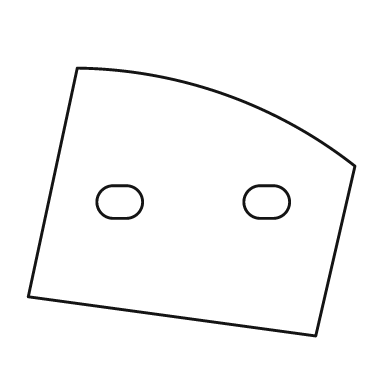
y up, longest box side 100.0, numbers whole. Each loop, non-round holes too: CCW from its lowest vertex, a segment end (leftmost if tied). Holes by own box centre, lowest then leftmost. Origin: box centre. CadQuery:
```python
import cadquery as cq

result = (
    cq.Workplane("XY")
    .moveTo(38.0, -41.0)
    .lineTo(50.0, 11.0)
    .threePointArc((10.0, 33.0), (-35.0, 41.0))
    .lineTo(-50.0, -29.0)
    .close()
    .moveTo(-24.0, -5.0)
    .lineTo(-20.0, -5.0)
    .threePointArc((-15.0, 0.0), (-20.0, 5.0))
    .lineTo(-24.0, 5.0)
    .threePointArc((-29.0, 0.0), (-24.0, -5.0))
    .close()
    .moveTo(21.0, -5.0)
    .lineTo(25.0, -5.0)
    .threePointArc((30.0, 0.0), (25.0, 5.0))
    .lineTo(21.0, 5.0)
    .threePointArc((16.0, 0.0), (21.0, -5.0))
    .close()
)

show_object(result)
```